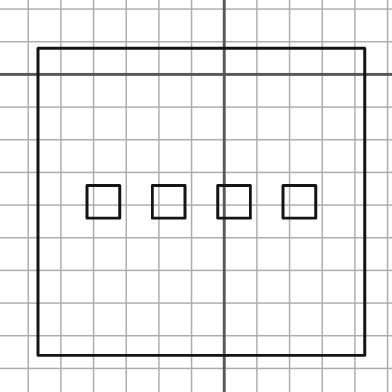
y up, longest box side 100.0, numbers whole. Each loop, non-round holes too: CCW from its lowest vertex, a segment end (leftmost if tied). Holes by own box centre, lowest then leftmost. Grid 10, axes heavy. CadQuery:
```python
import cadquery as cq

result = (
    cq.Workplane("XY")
    .moveTo(-57.0, -86.0)
    .lineTo(43.0, -86.0)
    .lineTo(43.0, 8.0)
    .lineTo(-57.0, 8.0)
    .close()
    .moveTo(-42.0, -44.0)
    .lineTo(-32.0, -44.0)
    .lineTo(-32.0, -34.0)
    .lineTo(-42.0, -34.0)
    .close()
    .moveTo(-22.0, -44.0)
    .lineTo(-12.0, -44.0)
    .lineTo(-12.0, -34.0)
    .lineTo(-22.0, -34.0)
    .close()
    .moveTo(-2.0, -44.0)
    .lineTo(8.0, -44.0)
    .lineTo(8.0, -34.0)
    .lineTo(-2.0, -34.0)
    .close()
    .moveTo(18.0, -44.0)
    .lineTo(28.0, -44.0)
    .lineTo(28.0, -34.0)
    .lineTo(18.0, -34.0)
    .close()
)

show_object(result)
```